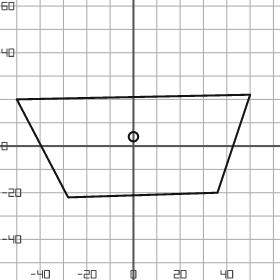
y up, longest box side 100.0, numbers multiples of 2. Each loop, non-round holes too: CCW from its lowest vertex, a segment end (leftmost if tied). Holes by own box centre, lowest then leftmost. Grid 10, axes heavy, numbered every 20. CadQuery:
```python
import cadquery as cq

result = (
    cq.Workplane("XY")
    .moveTo(-28.0, -22.0)
    .lineTo(36.0, -20.0)
    .lineTo(50.0, 22.0)
    .lineTo(-50.0, 20.0)
    .close()
    .moveTo(0.0, 4.0)
    .circle(2.0)
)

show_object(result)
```